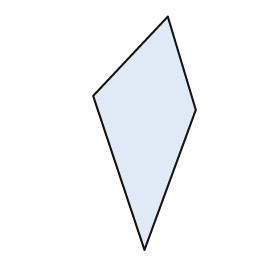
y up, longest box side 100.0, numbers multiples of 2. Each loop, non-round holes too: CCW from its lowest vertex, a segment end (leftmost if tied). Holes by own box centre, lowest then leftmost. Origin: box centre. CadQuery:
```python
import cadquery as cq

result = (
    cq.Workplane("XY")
    .moveTo(0.0, -50.0)
    .lineTo(22.0, 10.0)
    .lineTo(10.0, 50.0)
    .lineTo(-22.0, 16.0)
    .close()
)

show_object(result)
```